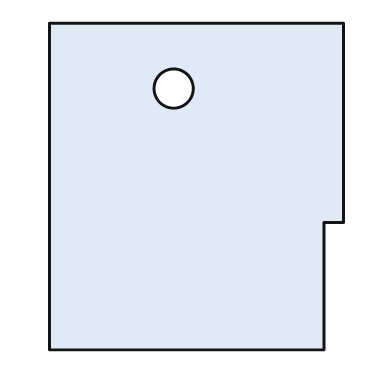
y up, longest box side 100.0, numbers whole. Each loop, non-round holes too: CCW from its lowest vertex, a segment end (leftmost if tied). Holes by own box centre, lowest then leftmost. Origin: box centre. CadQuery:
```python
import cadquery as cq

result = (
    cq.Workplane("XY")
    .moveTo(-45.0, -50.0)
    .lineTo(39.0, -50.0)
    .lineTo(39.0, -11.0)
    .lineTo(45.0, -11.0)
    .lineTo(45.0, 50.0)
    .lineTo(-45.0, 50.0)
    .close()
    .moveTo(-7.0, 30.0)
    .circle(6.0)
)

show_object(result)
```